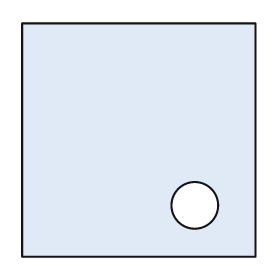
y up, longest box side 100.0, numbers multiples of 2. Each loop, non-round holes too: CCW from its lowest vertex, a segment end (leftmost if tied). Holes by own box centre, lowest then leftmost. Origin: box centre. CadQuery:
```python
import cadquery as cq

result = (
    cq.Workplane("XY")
    .moveTo(-50.0, -50.0)
    .lineTo(50.0, -50.0)
    .lineTo(50.0, 50.0)
    .lineTo(-50.0, 50.0)
    .close()
    .moveTo(24.0, -28.0)
    .circle(10.0)
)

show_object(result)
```